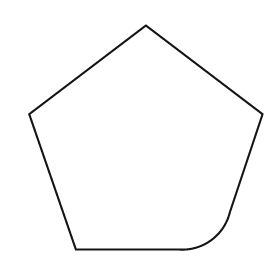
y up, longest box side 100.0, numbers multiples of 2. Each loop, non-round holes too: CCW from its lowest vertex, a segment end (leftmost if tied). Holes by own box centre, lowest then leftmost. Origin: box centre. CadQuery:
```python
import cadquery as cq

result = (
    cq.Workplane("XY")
    .moveTo(-30.0, -48.0)
    .lineTo(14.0, -48.0)
    .threePointArc((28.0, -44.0), (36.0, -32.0))
    .lineTo(50.0, 10.0)
    .lineTo(0.0, 48.0)
    .lineTo(-50.0, 10.0)
    .close()
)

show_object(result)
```